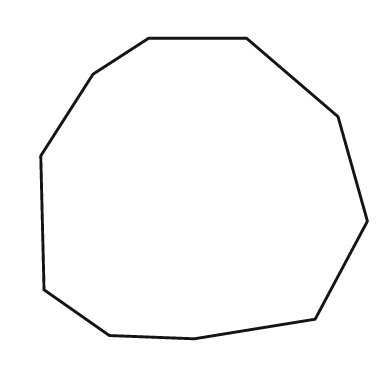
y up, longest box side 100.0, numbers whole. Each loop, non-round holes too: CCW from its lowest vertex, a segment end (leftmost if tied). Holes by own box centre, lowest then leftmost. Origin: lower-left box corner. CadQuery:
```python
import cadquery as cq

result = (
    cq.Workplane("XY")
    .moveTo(47.0, 0.0)
    .lineTo(84.0, 6.0)
    .lineTo(100.0, 36.0)
    .lineTo(91.0, 68.0)
    .lineTo(63.0, 92.0)
    .lineTo(33.0, 92.0)
    .lineTo(16.0, 81.0)
    .lineTo(0.0, 56.0)
    .lineTo(1.0, 15.0)
    .lineTo(21.0, 1.0)
    .close()
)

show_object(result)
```